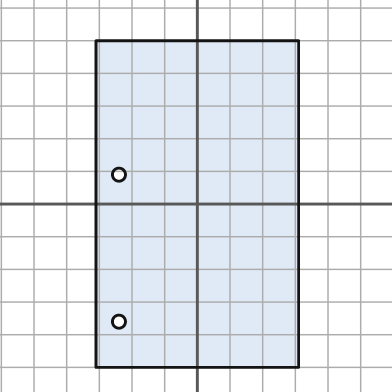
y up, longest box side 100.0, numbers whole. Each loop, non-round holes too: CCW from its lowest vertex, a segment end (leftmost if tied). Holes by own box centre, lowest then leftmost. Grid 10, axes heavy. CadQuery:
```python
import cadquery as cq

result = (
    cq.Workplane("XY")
    .moveTo(-31.0, -50.0)
    .lineTo(31.0, -50.0)
    .lineTo(31.0, 50.0)
    .lineTo(-31.0, 50.0)
    .close()
    .moveTo(-24.0, -36.0)
    .circle(2.0)
    .moveTo(-24.0, 9.0)
    .circle(2.0)
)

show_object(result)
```